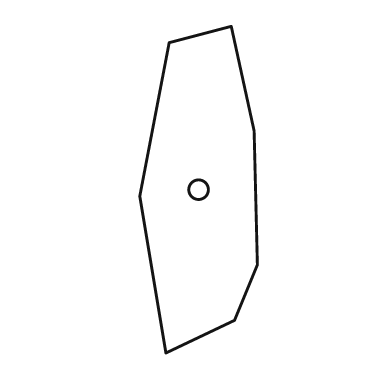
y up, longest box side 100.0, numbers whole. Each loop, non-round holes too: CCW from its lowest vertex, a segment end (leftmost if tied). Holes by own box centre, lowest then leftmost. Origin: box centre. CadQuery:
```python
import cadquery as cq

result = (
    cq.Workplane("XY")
    .moveTo(-10.0, -50.0)
    .lineTo(11.0, -40.0)
    .lineTo(18.0, -23.0)
    .lineTo(17.0, 18.0)
    .lineTo(10.0, 50.0)
    .lineTo(-9.0, 45.0)
    .lineTo(-18.0, -2.0)
    .close()
    .moveTo(0.0, 0.0)
    .circle(3.0)
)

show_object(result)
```